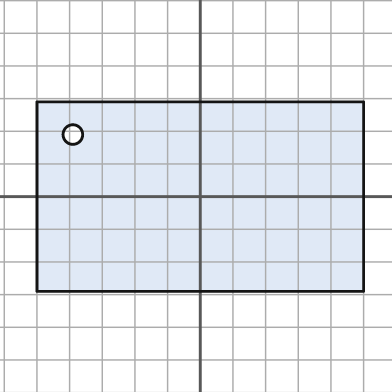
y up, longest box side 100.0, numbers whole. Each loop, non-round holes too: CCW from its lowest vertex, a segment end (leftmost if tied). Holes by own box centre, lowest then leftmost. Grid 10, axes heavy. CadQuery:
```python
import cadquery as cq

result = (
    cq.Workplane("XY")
    .moveTo(-50.0, -29.0)
    .lineTo(50.0, -29.0)
    .lineTo(50.0, 29.0)
    .lineTo(-50.0, 29.0)
    .close()
    .moveTo(-39.0, 19.0)
    .circle(3.0)
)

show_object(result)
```